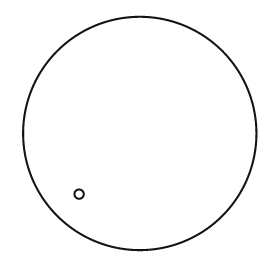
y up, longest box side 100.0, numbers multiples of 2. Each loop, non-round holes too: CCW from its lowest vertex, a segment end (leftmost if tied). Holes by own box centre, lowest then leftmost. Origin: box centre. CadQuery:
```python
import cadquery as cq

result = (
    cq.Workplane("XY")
    .moveTo(0.0, 0.0)
    .circle(50.0)
    .moveTo(-26.0, -26.0)
    .circle(2.0)
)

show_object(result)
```